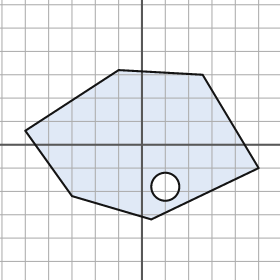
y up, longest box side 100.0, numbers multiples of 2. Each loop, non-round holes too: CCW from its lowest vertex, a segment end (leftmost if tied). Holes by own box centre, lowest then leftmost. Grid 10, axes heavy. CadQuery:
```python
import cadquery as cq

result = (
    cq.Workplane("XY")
    .moveTo(4.0, -32.0)
    .lineTo(50.0, -10.0)
    .lineTo(26.0, 30.0)
    .lineTo(-10.0, 32.0)
    .lineTo(-50.0, 6.0)
    .lineTo(-30.0, -22.0)
    .close()
    .moveTo(10.0, -18.0)
    .circle(6.0)
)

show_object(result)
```